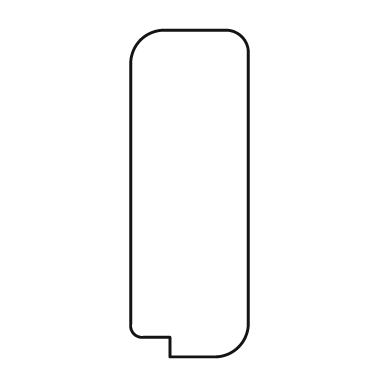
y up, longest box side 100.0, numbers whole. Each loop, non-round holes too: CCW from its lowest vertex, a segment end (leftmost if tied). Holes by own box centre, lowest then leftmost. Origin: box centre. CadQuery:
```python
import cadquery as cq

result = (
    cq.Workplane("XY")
    .moveTo(-6.0, -50.0)
    .lineTo(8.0, -50.0)
    .threePointArc((15.0, -47.0), (18.0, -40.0))
    .lineTo(18.0, 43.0)
    .threePointArc((16.0, 48.0), (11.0, 50.0))
    .lineTo(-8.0, 50.0)
    .threePointArc((-15.0, 47.0), (-18.0, 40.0))
    .lineTo(-18.0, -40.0)
    .threePointArc((-17.0, -43.0), (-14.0, -44.0))
    .lineTo(-6.0, -44.0)
    .close()
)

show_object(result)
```